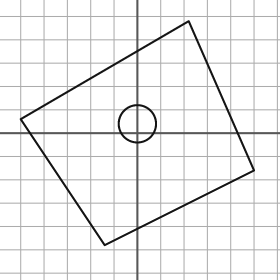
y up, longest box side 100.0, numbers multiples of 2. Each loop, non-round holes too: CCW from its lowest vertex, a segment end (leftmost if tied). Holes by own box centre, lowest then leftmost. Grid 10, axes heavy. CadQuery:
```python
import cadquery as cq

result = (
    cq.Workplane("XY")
    .moveTo(-14.0, -48.0)
    .lineTo(50.0, -16.0)
    .lineTo(22.0, 48.0)
    .lineTo(-50.0, 6.0)
    .close()
    .moveTo(0.0, 4.0)
    .circle(8.0)
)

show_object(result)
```